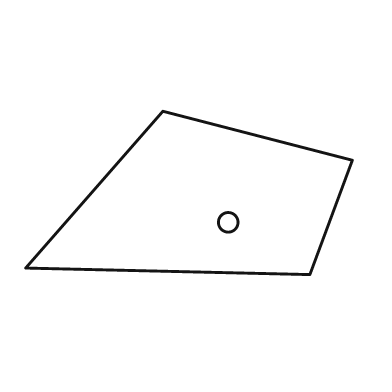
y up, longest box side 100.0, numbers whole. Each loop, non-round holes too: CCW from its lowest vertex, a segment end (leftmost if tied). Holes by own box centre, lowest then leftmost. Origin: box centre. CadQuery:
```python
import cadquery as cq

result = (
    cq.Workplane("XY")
    .moveTo(37.0, -25.0)
    .lineTo(50.0, 10.0)
    .lineTo(-8.0, 25.0)
    .lineTo(-50.0, -23.0)
    .close()
    .moveTo(12.0, -9.0)
    .circle(3.0)
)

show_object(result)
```